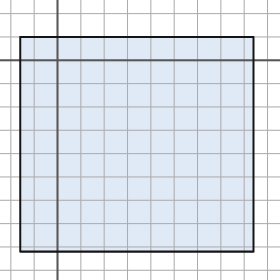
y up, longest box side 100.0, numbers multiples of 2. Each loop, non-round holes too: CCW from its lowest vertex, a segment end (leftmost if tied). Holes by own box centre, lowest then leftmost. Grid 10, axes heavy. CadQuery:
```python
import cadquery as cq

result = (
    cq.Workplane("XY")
    .moveTo(-16.0, -82.0)
    .lineTo(84.0, -82.0)
    .lineTo(84.0, 10.0)
    .lineTo(-16.0, 10.0)
    .close()
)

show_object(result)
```